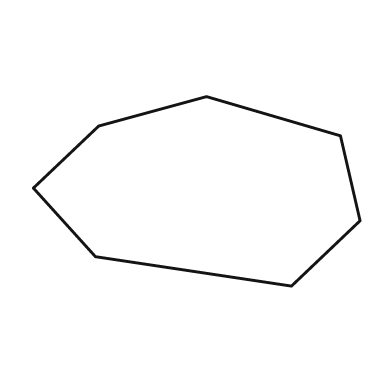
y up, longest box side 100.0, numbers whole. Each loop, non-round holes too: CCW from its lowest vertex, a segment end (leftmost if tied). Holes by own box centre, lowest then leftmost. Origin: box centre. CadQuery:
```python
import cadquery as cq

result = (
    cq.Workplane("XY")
    .moveTo(29.0, -29.0)
    .lineTo(50.0, -9.0)
    .lineTo(44.0, 17.0)
    .lineTo(3.0, 29.0)
    .lineTo(-30.0, 20.0)
    .lineTo(-50.0, 1.0)
    .lineTo(-31.0, -20.0)
    .close()
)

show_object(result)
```